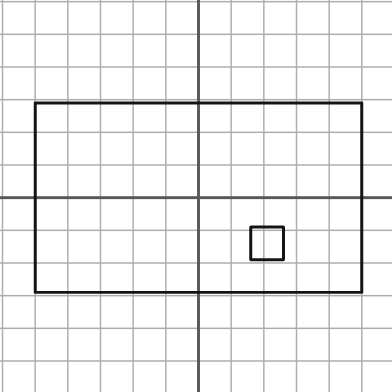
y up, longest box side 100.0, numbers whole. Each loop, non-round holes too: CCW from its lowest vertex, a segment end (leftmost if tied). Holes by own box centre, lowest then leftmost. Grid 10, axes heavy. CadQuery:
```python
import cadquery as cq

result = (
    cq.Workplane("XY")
    .moveTo(-50.0, -29.0)
    .lineTo(50.0, -29.0)
    .lineTo(50.0, 29.0)
    .lineTo(-50.0, 29.0)
    .close()
    .moveTo(16.0, -19.0)
    .lineTo(26.0, -19.0)
    .lineTo(26.0, -9.0)
    .lineTo(16.0, -9.0)
    .close()
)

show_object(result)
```